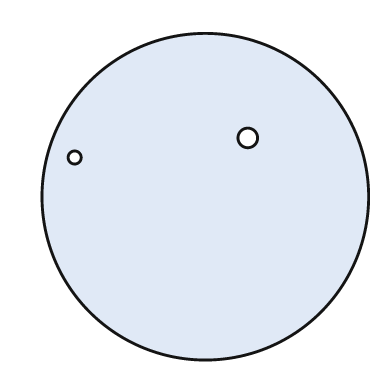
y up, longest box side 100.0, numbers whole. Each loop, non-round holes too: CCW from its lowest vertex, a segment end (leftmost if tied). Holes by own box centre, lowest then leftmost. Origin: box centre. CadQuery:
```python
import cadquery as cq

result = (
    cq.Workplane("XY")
    .moveTo(0.0, 0.0)
    .circle(50.0)
    .moveTo(-40.0, 12.0)
    .circle(2.0)
    .moveTo(13.0, 18.0)
    .circle(3.0)
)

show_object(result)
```